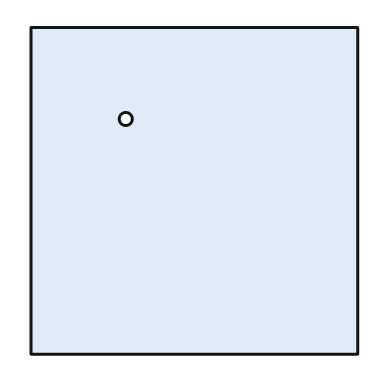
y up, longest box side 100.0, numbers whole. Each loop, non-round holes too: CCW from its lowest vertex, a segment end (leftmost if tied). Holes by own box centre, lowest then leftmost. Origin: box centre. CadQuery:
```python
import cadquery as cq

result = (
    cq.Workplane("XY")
    .moveTo(-50.0, -50.0)
    .lineTo(50.0, -50.0)
    .lineTo(50.0, 50.0)
    .lineTo(-50.0, 50.0)
    .close()
    .moveTo(-21.0, 22.0)
    .circle(2.0)
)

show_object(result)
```